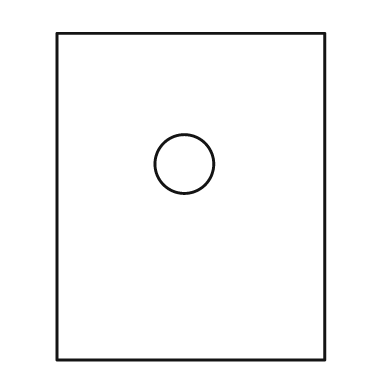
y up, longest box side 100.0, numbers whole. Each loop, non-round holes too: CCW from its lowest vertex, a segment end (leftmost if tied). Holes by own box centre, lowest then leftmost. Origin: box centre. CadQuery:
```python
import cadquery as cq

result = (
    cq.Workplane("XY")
    .moveTo(-41.0, -50.0)
    .lineTo(41.0, -50.0)
    .lineTo(41.0, 50.0)
    .lineTo(-41.0, 50.0)
    .close()
    .moveTo(-2.0, 10.0)
    .circle(9.0)
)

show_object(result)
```